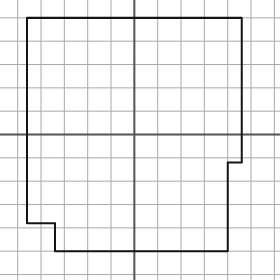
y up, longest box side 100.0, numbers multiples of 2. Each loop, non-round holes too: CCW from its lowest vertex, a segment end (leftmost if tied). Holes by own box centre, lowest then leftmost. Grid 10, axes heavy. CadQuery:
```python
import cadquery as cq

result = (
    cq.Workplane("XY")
    .moveTo(-34.0, -50.0)
    .lineTo(40.0, -50.0)
    .lineTo(40.0, -12.0)
    .lineTo(46.0, -12.0)
    .lineTo(46.0, 50.0)
    .lineTo(-46.0, 50.0)
    .lineTo(-46.0, -38.0)
    .lineTo(-34.0, -38.0)
    .close()
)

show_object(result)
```